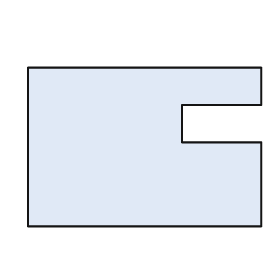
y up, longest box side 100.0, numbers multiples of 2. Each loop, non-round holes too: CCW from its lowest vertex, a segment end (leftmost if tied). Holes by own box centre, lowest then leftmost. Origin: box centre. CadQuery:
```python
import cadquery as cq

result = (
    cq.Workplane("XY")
    .moveTo(-50.0, -34.0)
    .lineTo(50.0, -34.0)
    .lineTo(50.0, 2.0)
    .lineTo(16.0, 2.0)
    .lineTo(16.0, 18.0)
    .lineTo(50.0, 18.0)
    .lineTo(50.0, 34.0)
    .lineTo(-50.0, 34.0)
    .close()
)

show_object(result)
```